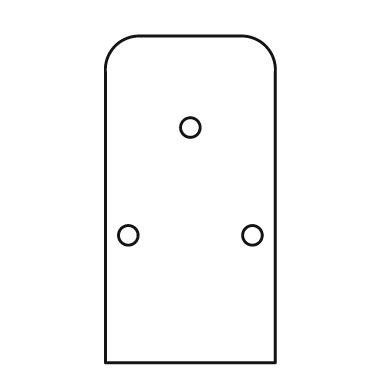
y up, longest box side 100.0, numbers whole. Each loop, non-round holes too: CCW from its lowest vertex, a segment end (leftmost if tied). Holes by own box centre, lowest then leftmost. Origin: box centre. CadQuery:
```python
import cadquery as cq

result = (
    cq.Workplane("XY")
    .moveTo(-26.0, -50.0)
    .lineTo(26.0, -50.0)
    .lineTo(26.0, 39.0)
    .threePointArc((23.0, 47.0), (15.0, 50.0))
    .lineTo(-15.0, 50.0)
    .threePointArc((-23.0, 47.0), (-26.0, 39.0))
    .close()
    .moveTo(-19.0, -11.0)
    .circle(3.0)
    .moveTo(19.0, -11.0)
    .circle(3.0)
    .moveTo(0.0, 22.0)
    .circle(3.0)
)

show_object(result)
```